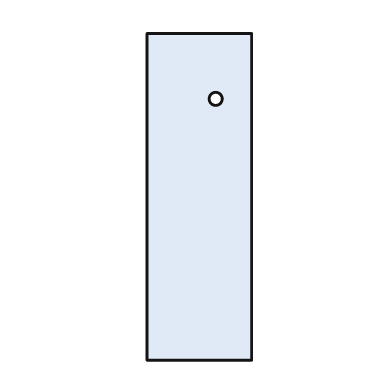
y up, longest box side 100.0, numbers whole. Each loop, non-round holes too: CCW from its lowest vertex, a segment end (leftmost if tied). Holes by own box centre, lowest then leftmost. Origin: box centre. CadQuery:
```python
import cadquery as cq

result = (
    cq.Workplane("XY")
    .moveTo(-16.0, -50.0)
    .lineTo(16.0, -50.0)
    .lineTo(16.0, 50.0)
    .lineTo(-16.0, 50.0)
    .close()
    .moveTo(5.0, 30.0)
    .circle(2.0)
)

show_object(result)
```